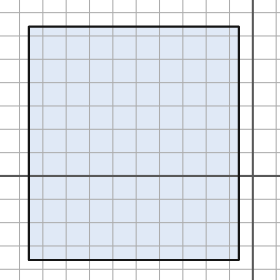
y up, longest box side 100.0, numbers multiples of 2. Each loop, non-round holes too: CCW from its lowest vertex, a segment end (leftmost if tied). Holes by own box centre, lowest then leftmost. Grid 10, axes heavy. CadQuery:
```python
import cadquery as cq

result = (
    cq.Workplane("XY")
    .moveTo(-96.0, -36.0)
    .lineTo(-6.0, -36.0)
    .lineTo(-6.0, 64.0)
    .lineTo(-96.0, 64.0)
    .close()
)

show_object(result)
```